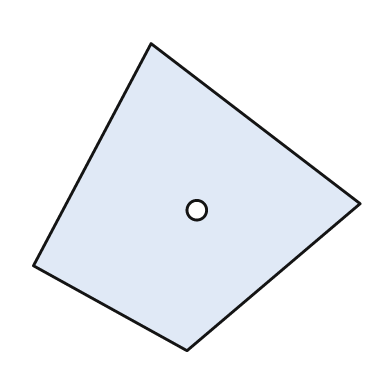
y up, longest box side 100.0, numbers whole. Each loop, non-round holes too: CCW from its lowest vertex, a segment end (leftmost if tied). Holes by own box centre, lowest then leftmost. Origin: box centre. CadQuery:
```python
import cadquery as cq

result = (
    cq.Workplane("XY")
    .moveTo(-3.0, -47.0)
    .lineTo(50.0, -2.0)
    .lineTo(-14.0, 47.0)
    .lineTo(-50.0, -21.0)
    .close()
    .moveTo(0.0, -4.0)
    .circle(3.0)
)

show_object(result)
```